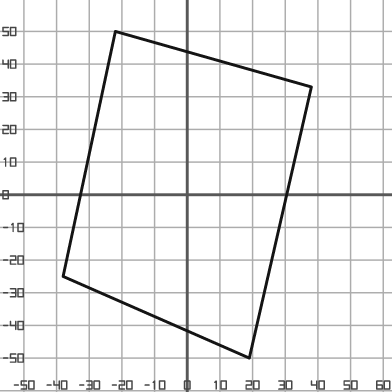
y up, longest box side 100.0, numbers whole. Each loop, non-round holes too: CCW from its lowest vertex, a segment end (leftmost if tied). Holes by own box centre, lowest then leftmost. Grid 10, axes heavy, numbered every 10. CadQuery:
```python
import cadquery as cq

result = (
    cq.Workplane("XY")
    .moveTo(19.0, -50.0)
    .lineTo(38.0, 33.0)
    .lineTo(-22.0, 50.0)
    .lineTo(-38.0, -25.0)
    .close()
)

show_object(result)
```